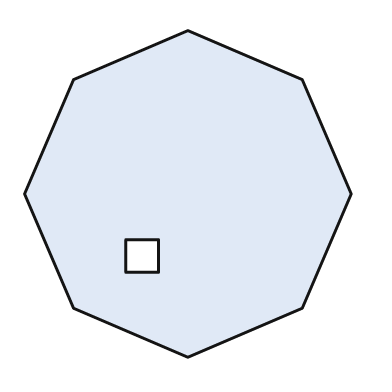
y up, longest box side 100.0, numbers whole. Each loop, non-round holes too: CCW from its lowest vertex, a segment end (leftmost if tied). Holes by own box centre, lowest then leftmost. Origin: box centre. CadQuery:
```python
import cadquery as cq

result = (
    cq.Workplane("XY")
    .moveTo(0.0, -50.0)
    .lineTo(35.0, -35.0)
    .lineTo(50.0, 0.0)
    .lineTo(35.0, 35.0)
    .lineTo(0.0, 50.0)
    .lineTo(-35.0, 35.0)
    .lineTo(-50.0, 0.0)
    .lineTo(-35.0, -35.0)
    .close()
    .moveTo(-19.0, -24.0)
    .lineTo(-9.0, -24.0)
    .lineTo(-9.0, -14.0)
    .lineTo(-19.0, -14.0)
    .close()
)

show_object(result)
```